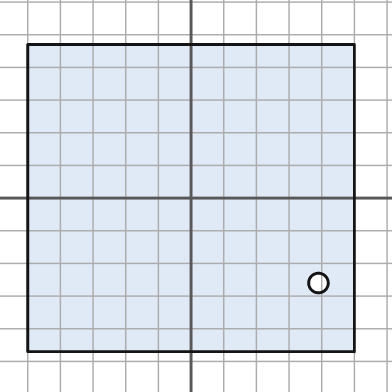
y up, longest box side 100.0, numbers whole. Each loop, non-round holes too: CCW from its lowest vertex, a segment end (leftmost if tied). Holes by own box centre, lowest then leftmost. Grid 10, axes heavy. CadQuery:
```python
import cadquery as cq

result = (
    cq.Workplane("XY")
    .moveTo(-50.0, -47.0)
    .lineTo(50.0, -47.0)
    .lineTo(50.0, 47.0)
    .lineTo(-50.0, 47.0)
    .close()
    .moveTo(39.0, -26.0)
    .circle(3.0)
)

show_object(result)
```